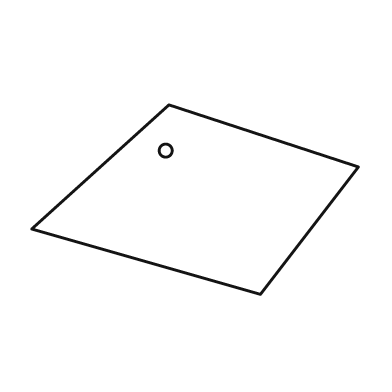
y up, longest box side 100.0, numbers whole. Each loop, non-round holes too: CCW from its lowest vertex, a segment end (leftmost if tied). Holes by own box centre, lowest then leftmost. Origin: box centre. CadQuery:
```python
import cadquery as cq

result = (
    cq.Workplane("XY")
    .moveTo(20.0, -29.0)
    .lineTo(50.0, 10.0)
    .lineTo(-8.0, 29.0)
    .lineTo(-50.0, -9.0)
    .close()
    .moveTo(-9.0, 15.0)
    .circle(2.0)
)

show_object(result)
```